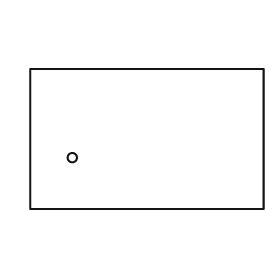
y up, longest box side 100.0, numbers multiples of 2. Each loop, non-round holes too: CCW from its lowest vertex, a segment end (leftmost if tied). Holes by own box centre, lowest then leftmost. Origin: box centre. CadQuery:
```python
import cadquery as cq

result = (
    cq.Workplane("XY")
    .moveTo(-50.0, -30.0)
    .lineTo(50.0, -30.0)
    .lineTo(50.0, 30.0)
    .lineTo(-50.0, 30.0)
    .close()
    .moveTo(-32.0, -8.0)
    .circle(2.0)
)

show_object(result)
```